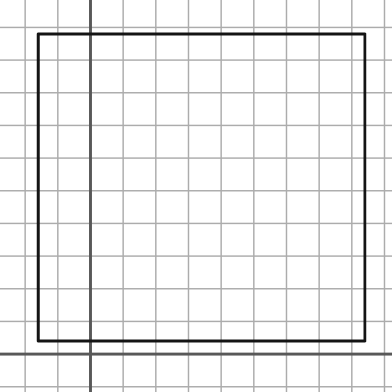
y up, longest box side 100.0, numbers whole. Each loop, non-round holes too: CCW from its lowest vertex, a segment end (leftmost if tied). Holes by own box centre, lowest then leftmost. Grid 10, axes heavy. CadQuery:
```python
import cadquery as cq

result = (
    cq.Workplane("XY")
    .moveTo(-16.0, 4.0)
    .lineTo(84.0, 4.0)
    .lineTo(84.0, 98.0)
    .lineTo(-16.0, 98.0)
    .close()
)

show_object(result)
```